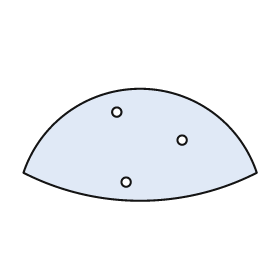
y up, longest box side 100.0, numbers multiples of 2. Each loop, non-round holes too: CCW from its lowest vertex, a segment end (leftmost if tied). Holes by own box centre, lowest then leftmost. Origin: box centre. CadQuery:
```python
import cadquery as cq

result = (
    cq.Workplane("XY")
    .moveTo(-50.0, -12.0)
    .threePointArc((0.0, -24.0), (50.0, -12.0))
    .threePointArc((0.0, 24.0), (-50.0, -12.0))
    .close()
    .moveTo(-6.0, -16.0)
    .circle(2.0)
    .moveTo(18.0, 2.0)
    .circle(2.0)
    .moveTo(-10.0, 14.0)
    .circle(2.0)
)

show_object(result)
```